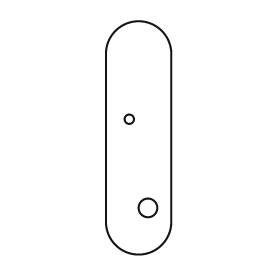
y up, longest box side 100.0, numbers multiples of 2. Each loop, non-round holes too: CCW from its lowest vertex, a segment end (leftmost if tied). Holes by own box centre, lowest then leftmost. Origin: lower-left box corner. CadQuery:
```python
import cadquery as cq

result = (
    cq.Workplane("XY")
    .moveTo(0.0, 14.0)
    .threePointArc((14.0, 0.0), (28.0, 14.0))
    .lineTo(28.0, 86.0)
    .threePointArc((14.0, 100.0), (0.0, 86.0))
    .close()
    .moveTo(18.0, 20.0)
    .circle(4.0)
    .moveTo(10.0, 58.0)
    .circle(2.0)
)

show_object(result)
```